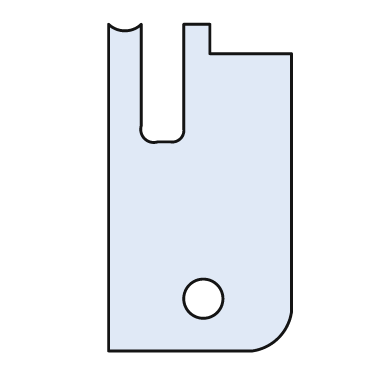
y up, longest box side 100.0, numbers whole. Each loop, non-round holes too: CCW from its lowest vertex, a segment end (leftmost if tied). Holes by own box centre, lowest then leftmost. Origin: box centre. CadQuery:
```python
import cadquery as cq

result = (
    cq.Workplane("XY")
    .moveTo(-28.0, -50.0)
    .lineTo(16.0, -50.0)
    .threePointArc((24.0, -46.0), (28.0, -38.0))
    .lineTo(28.0, 41.0)
    .lineTo(3.0, 41.0)
    .lineTo(3.0, 50.0)
    .lineTo(-5.0, 50.0)
    .lineTo(-5.0, 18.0)
    .threePointArc((-6.0, 15.0), (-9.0, 14.0))
    .lineTo(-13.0, 14.0)
    .threePointArc((-17.0, 15.0), (-18.0, 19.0))
    .lineTo(-18.0, 50.0)
    .threePointArc((-23.0, 48.0), (-28.0, 50.0))
    .close()
    .moveTo(1.0, -34.0)
    .circle(6.0)
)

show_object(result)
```